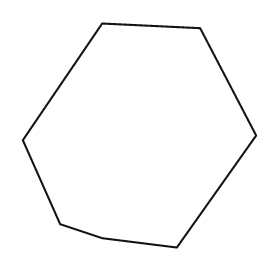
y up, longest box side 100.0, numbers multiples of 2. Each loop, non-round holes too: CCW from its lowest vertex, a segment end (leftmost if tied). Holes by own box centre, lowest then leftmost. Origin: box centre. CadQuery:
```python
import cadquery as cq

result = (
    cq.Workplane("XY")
    .moveTo(16.0, -48.0)
    .lineTo(50.0, 0.0)
    .lineTo(26.0, 46.0)
    .lineTo(-16.0, 48.0)
    .lineTo(-50.0, -2.0)
    .lineTo(-34.0, -38.0)
    .lineTo(-16.0, -44.0)
    .close()
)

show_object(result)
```